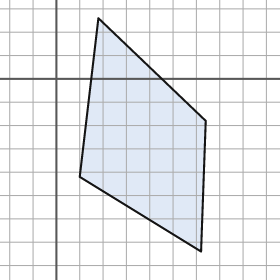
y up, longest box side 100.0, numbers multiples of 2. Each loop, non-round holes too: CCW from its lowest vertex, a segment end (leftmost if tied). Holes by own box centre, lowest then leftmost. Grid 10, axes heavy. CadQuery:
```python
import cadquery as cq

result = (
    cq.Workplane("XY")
    .moveTo(62.0, -74.0)
    .lineTo(64.0, -18.0)
    .lineTo(18.0, 26.0)
    .lineTo(10.0, -42.0)
    .close()
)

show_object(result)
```